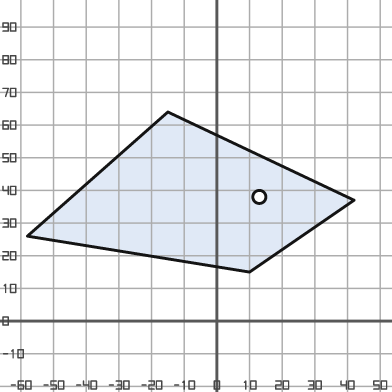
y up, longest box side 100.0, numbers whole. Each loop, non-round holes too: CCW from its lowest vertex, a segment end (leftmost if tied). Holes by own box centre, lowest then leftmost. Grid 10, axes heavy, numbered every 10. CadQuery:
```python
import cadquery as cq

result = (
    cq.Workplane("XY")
    .moveTo(10.0, 15.0)
    .lineTo(42.0, 37.0)
    .lineTo(-15.0, 64.0)
    .lineTo(-58.0, 26.0)
    .close()
    .moveTo(13.0, 38.0)
    .circle(2.0)
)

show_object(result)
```